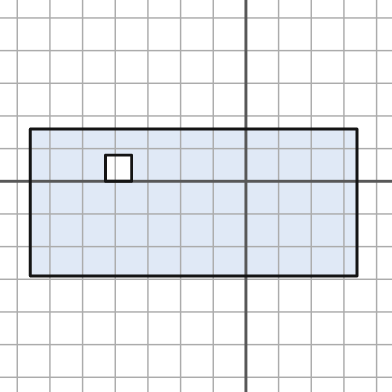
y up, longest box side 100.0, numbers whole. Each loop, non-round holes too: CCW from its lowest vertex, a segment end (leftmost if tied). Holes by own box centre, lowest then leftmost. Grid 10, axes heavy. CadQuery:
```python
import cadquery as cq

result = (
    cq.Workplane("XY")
    .moveTo(-66.0, -29.0)
    .lineTo(34.0, -29.0)
    .lineTo(34.0, 16.0)
    .lineTo(-66.0, 16.0)
    .close()
    .moveTo(-43.0, 0.0)
    .lineTo(-35.0, 0.0)
    .lineTo(-35.0, 8.0)
    .lineTo(-43.0, 8.0)
    .close()
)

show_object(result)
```